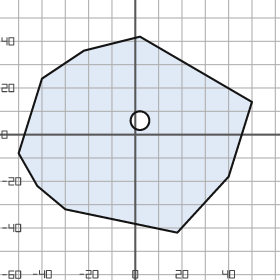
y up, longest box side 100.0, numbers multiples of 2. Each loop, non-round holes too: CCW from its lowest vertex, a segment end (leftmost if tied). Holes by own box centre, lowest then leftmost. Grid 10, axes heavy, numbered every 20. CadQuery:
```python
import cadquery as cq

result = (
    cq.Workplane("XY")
    .moveTo(18.0, -42.0)
    .lineTo(40.0, -18.0)
    .lineTo(50.0, 14.0)
    .lineTo(2.0, 42.0)
    .lineTo(-22.0, 36.0)
    .lineTo(-40.0, 24.0)
    .lineTo(-50.0, -8.0)
    .lineTo(-42.0, -22.0)
    .lineTo(-30.0, -32.0)
    .close()
    .moveTo(2.0, 6.0)
    .circle(4.0)
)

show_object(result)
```